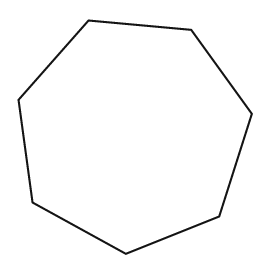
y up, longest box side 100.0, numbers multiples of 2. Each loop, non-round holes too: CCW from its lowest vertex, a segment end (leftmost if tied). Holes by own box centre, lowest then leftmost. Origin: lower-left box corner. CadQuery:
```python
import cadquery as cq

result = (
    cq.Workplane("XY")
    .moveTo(46.0, 0.0)
    .lineTo(86.0, 16.0)
    .lineTo(100.0, 60.0)
    .lineTo(74.0, 96.0)
    .lineTo(30.0, 100.0)
    .lineTo(0.0, 66.0)
    .lineTo(6.0, 22.0)
    .close()
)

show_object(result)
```